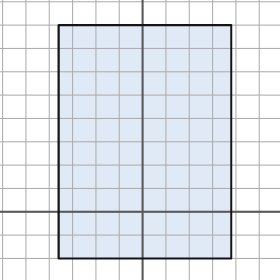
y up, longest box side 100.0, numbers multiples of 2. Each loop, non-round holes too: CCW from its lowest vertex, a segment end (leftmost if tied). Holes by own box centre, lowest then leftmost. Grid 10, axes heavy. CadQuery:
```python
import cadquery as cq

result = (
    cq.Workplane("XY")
    .moveTo(-36.0, -20.0)
    .lineTo(38.0, -20.0)
    .lineTo(38.0, 80.0)
    .lineTo(-36.0, 80.0)
    .close()
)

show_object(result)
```